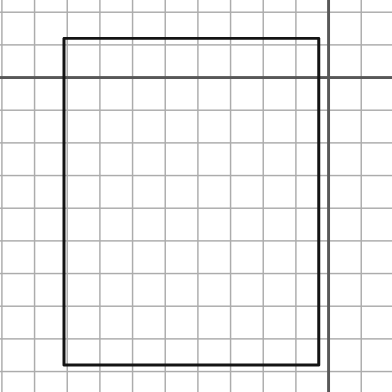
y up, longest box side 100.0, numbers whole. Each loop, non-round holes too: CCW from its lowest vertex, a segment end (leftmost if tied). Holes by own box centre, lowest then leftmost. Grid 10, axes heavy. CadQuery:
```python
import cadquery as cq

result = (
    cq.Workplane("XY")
    .moveTo(-81.0, -88.0)
    .lineTo(-3.0, -88.0)
    .lineTo(-3.0, 12.0)
    .lineTo(-81.0, 12.0)
    .close()
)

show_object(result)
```